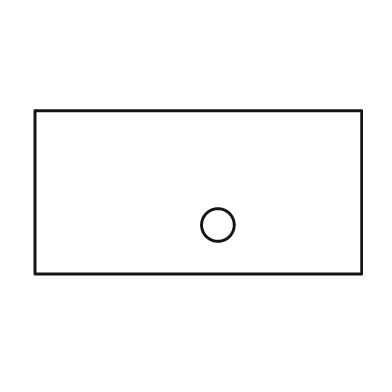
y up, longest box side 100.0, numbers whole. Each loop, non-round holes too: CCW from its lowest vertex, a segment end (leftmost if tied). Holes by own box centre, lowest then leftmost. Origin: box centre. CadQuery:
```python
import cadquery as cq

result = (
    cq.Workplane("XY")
    .moveTo(-50.0, -25.0)
    .lineTo(50.0, -25.0)
    .lineTo(50.0, 25.0)
    .lineTo(-50.0, 25.0)
    .close()
    .moveTo(6.0, -10.0)
    .circle(5.0)
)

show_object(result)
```